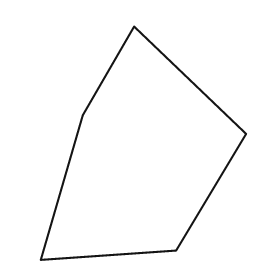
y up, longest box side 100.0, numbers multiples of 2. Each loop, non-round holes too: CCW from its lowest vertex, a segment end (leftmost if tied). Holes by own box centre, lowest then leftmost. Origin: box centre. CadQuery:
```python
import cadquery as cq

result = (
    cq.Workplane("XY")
    .moveTo(-44.0, -50.0)
    .lineTo(14.0, -46.0)
    .lineTo(44.0, 4.0)
    .lineTo(-4.0, 50.0)
    .lineTo(-26.0, 12.0)
    .close()
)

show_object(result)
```